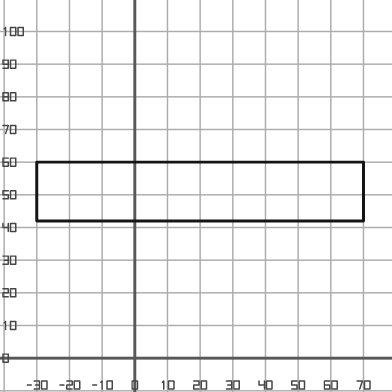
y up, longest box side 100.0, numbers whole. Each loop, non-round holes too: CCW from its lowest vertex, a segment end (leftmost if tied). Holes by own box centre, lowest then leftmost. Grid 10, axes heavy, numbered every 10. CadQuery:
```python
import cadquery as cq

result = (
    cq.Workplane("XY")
    .moveTo(-30.0, 42.0)
    .lineTo(70.0, 42.0)
    .lineTo(70.0, 60.0)
    .lineTo(-30.0, 60.0)
    .close()
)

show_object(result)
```